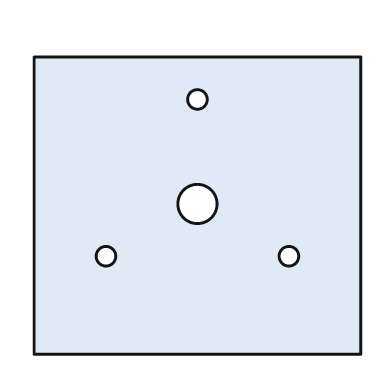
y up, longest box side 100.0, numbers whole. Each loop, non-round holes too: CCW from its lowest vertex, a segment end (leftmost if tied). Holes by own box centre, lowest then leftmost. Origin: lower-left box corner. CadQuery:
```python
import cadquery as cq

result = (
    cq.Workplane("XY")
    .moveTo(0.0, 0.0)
    .lineTo(100.0, 0.0)
    .lineTo(100.0, 91.0)
    .lineTo(0.0, 91.0)
    .close()
    .moveTo(22.0, 30.0)
    .circle(3.0)
    .moveTo(78.0, 30.0)
    .circle(3.0)
    .moveTo(50.0, 46.0)
    .circle(6.0)
    .moveTo(50.0, 78.0)
    .circle(3.0)
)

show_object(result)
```